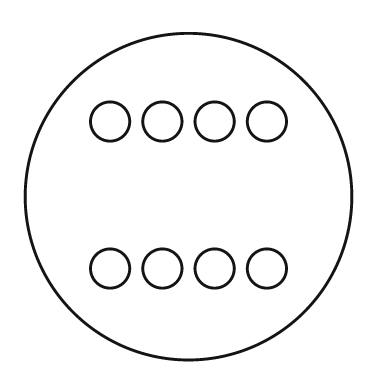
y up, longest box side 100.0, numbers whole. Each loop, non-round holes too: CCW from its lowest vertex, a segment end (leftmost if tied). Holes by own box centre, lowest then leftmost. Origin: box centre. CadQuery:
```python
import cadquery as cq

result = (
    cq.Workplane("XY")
    .moveTo(0.0, 0.0)
    .circle(50.0)
    .moveTo(-24.0, -22.0)
    .circle(6.0)
    .moveTo(-8.0, -22.0)
    .circle(6.0)
    .moveTo(8.0, -22.0)
    .circle(6.0)
    .moveTo(24.0, -22.0)
    .circle(6.0)
    .moveTo(-24.0, 23.0)
    .circle(6.0)
    .moveTo(-8.0, 23.0)
    .circle(6.0)
    .moveTo(8.0, 23.0)
    .circle(6.0)
    .moveTo(24.0, 23.0)
    .circle(6.0)
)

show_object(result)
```